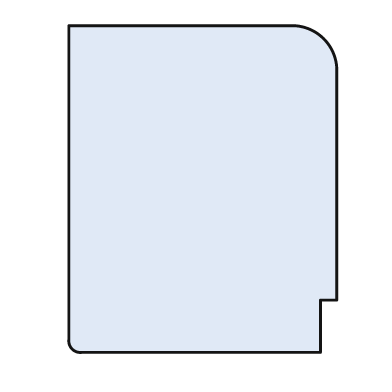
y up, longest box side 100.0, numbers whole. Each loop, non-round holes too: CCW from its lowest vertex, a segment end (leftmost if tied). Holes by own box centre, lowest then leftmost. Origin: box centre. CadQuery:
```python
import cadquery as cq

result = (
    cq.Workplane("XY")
    .moveTo(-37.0, -50.0)
    .lineTo(36.0, -50.0)
    .lineTo(36.0, -34.0)
    .lineTo(41.0, -34.0)
    .lineTo(41.0, 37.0)
    .threePointArc((37.0, 46.0), (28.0, 50.0))
    .lineTo(-41.0, 50.0)
    .lineTo(-41.0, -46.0)
    .threePointArc((-40.0, -49.0), (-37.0, -50.0))
    .close()
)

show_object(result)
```